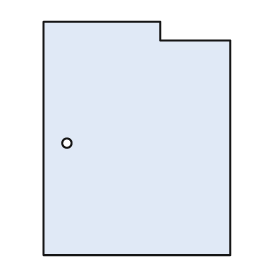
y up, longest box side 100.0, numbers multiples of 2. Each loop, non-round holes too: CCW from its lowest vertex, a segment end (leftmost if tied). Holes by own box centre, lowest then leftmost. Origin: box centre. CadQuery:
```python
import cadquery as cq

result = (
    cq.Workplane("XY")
    .moveTo(-40.0, -50.0)
    .lineTo(40.0, -50.0)
    .lineTo(40.0, 42.0)
    .lineTo(10.0, 42.0)
    .lineTo(10.0, 50.0)
    .lineTo(-40.0, 50.0)
    .close()
    .moveTo(-30.0, -2.0)
    .circle(2.0)
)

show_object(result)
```